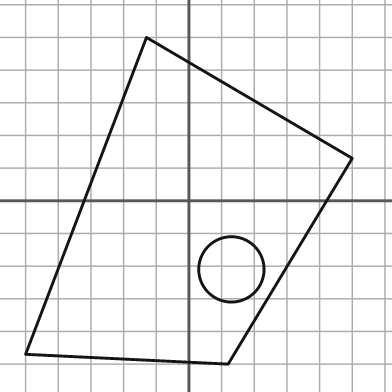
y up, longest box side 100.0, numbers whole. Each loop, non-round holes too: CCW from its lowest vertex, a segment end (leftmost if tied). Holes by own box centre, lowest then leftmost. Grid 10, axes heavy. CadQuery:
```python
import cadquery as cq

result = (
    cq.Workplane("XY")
    .moveTo(12.0, -50.0)
    .lineTo(50.0, 13.0)
    .lineTo(-13.0, 50.0)
    .lineTo(-50.0, -47.0)
    .close()
    .moveTo(13.0, -21.0)
    .circle(10.0)
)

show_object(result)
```